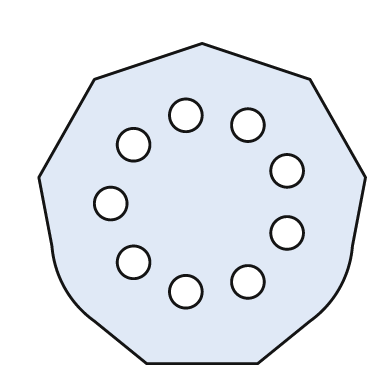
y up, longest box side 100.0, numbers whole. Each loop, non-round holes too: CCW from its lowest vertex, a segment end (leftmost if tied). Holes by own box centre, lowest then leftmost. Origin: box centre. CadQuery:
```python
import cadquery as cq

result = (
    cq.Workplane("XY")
    .moveTo(-17.0, -49.0)
    .lineTo(17.0, -49.0)
    .lineTo(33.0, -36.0)
    .threePointArc((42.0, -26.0), (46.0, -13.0))
    .lineTo(50.0, 8.0)
    .lineTo(33.0, 38.0)
    .lineTo(0.0, 49.0)
    .lineTo(-33.0, 38.0)
    .lineTo(-50.0, 8.0)
    .lineTo(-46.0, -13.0)
    .threePointArc((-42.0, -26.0), (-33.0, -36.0))
    .close()
    .moveTo(-5.0, -27.0)
    .circle(5.0)
    .moveTo(14.0, -24.0)
    .circle(5.0)
    .moveTo(-21.0, -18.0)
    .circle(5.0)
    .moveTo(26.0, -9.0)
    .circle(5.0)
    .moveTo(-28.0, 0.0)
    .circle(5.0)
    .moveTo(26.0, 10.0)
    .circle(5.0)
    .moveTo(-21.0, 18.0)
    .circle(5.0)
    .moveTo(14.0, 24.0)
    .circle(5.0)
    .moveTo(-5.0, 27.0)
    .circle(5.0)
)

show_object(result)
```